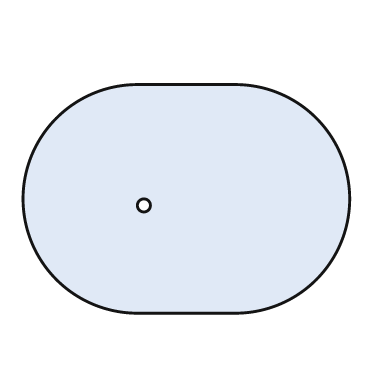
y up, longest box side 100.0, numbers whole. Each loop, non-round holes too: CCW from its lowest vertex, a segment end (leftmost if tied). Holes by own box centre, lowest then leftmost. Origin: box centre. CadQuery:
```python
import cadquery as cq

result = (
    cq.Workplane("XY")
    .moveTo(-15.0, -35.0)
    .lineTo(15.0, -35.0)
    .threePointArc((50.0, 0.0), (15.0, 35.0))
    .lineTo(-15.0, 35.0)
    .threePointArc((-50.0, 0.0), (-15.0, -35.0))
    .close()
    .moveTo(-13.0, -2.0)
    .circle(2.0)
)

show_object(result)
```